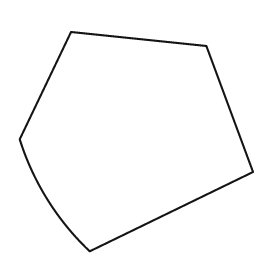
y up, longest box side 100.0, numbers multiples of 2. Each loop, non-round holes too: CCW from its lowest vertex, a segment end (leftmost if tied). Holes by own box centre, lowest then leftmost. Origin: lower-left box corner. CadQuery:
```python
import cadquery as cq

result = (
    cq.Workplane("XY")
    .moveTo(30.0, 0.0)
    .lineTo(100.0, 34.0)
    .lineTo(80.0, 88.0)
    .lineTo(22.0, 94.0)
    .lineTo(0.0, 48.0)
    .threePointArc((12.0, 22.0), (30.0, 0.0))
    .close()
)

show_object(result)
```